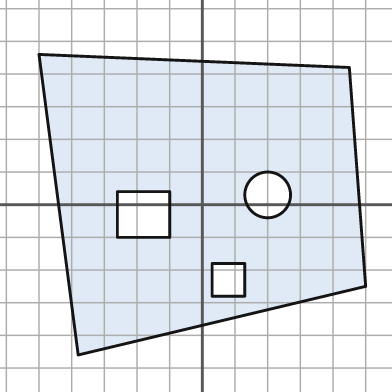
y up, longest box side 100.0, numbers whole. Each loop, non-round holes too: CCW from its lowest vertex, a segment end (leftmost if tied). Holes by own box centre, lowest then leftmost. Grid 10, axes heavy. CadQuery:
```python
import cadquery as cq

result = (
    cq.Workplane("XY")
    .moveTo(-38.0, -46.0)
    .lineTo(50.0, -25.0)
    .lineTo(45.0, 42.0)
    .lineTo(-50.0, 46.0)
    .close()
    .moveTo(3.0, -28.0)
    .lineTo(13.0, -28.0)
    .lineTo(13.0, -18.0)
    .lineTo(3.0, -18.0)
    .close()
    .moveTo(-26.0, -10.0)
    .lineTo(-10.0, -10.0)
    .lineTo(-10.0, 4.0)
    .lineTo(-26.0, 4.0)
    .close()
    .moveTo(20.0, 3.0)
    .circle(7.0)
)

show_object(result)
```